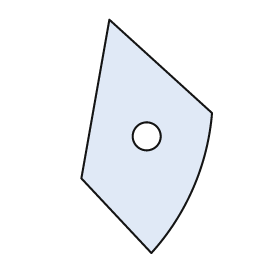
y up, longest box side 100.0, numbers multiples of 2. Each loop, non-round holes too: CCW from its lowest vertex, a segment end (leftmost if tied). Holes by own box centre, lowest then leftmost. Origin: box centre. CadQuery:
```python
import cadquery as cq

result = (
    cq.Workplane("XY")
    .moveTo(2.0, -50.0)
    .threePointArc((20.0, -22.0), (28.0, 10.0))
    .lineTo(-16.0, 50.0)
    .lineTo(-28.0, -18.0)
    .close()
    .moveTo(0.0, 0.0)
    .circle(6.0)
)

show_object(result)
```